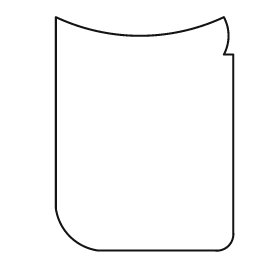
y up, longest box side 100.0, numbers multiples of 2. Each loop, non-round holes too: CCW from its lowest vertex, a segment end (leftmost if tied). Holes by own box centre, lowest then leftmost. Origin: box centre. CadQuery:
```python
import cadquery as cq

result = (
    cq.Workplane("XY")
    .moveTo(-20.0, -50.0)
    .lineTo(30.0, -50.0)
    .threePointArc((36.0, -48.0), (38.0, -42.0))
    .lineTo(38.0, 34.0)
    .lineTo(34.0, 34.0)
    .threePointArc((36.0, 42.0), (34.0, 50.0))
    .threePointArc((-2.0, 42.0), (-38.0, 50.0))
    .lineTo(-38.0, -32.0)
    .threePointArc((-32.0, -44.0), (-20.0, -50.0))
    .close()
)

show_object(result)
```